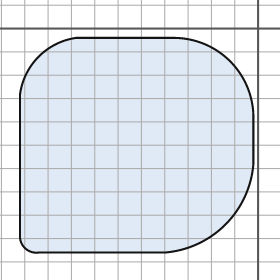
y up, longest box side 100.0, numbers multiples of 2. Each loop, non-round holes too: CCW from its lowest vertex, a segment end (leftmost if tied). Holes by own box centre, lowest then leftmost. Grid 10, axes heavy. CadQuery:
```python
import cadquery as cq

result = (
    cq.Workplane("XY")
    .moveTo(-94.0, -96.0)
    .lineTo(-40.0, -96.0)
    .threePointArc((-14.0, -84.0), (-2.0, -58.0))
    .lineTo(-2.0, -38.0)
    .threePointArc((-12.0, -14.0), (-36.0, -4.0))
    .lineTo(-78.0, -4.0)
    .threePointArc((-94.0, -12.0), (-102.0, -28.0))
    .lineTo(-102.0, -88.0)
    .threePointArc((-100.0, -94.0), (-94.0, -96.0))
    .close()
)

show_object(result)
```